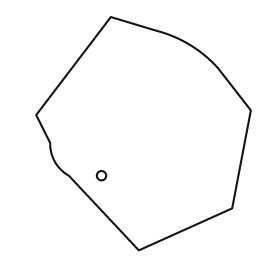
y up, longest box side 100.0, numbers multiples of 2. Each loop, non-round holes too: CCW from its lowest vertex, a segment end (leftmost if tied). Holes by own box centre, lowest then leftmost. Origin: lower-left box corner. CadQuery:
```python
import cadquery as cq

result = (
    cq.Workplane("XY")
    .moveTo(44.0, 0.0)
    .lineTo(84.0, 18.0)
    .lineTo(92.0, 60.0)
    .lineTo(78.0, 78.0)
    .threePointArc((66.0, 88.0), (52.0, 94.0))
    .lineTo(32.0, 100.0)
    .lineTo(0.0, 58.0)
    .lineTo(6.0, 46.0)
    .threePointArc((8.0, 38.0), (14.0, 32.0))
    .close()
    .moveTo(28.0, 32.0)
    .circle(2.0)
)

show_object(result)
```